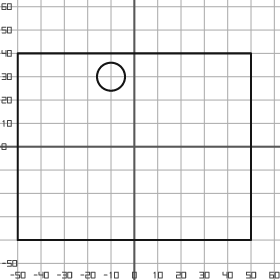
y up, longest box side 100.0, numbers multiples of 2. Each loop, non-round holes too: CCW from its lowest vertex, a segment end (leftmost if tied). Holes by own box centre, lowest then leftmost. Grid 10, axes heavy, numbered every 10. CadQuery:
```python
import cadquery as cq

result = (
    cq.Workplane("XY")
    .moveTo(-50.0, -40.0)
    .lineTo(50.0, -40.0)
    .lineTo(50.0, 40.0)
    .lineTo(-50.0, 40.0)
    .close()
    .moveTo(-10.0, 30.0)
    .circle(6.0)
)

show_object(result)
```